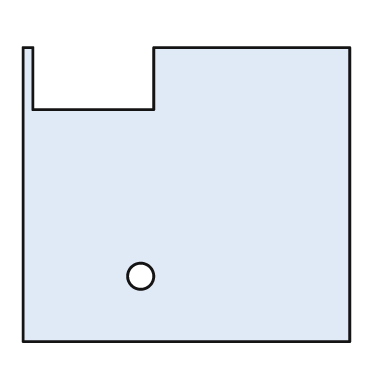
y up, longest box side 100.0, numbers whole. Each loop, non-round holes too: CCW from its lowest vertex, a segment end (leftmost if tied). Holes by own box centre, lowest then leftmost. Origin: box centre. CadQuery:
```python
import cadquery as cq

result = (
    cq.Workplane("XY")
    .moveTo(-50.0, -45.0)
    .lineTo(50.0, -45.0)
    .lineTo(50.0, 45.0)
    .lineTo(-10.0, 45.0)
    .lineTo(-10.0, 26.0)
    .lineTo(-47.0, 26.0)
    .lineTo(-47.0, 45.0)
    .lineTo(-50.0, 45.0)
    .close()
    .moveTo(-14.0, -25.0)
    .circle(4.0)
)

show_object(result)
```